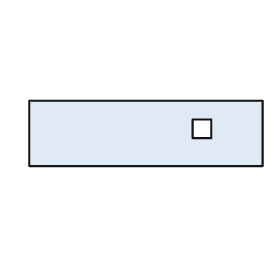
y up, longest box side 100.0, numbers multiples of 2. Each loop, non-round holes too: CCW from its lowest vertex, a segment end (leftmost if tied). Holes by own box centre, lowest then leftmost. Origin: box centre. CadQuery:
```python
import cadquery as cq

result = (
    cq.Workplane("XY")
    .moveTo(-50.0, -14.0)
    .lineTo(50.0, -14.0)
    .lineTo(50.0, 14.0)
    .lineTo(-50.0, 14.0)
    .close()
    .moveTo(20.0, -2.0)
    .lineTo(28.0, -2.0)
    .lineTo(28.0, 6.0)
    .lineTo(20.0, 6.0)
    .close()
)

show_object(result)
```